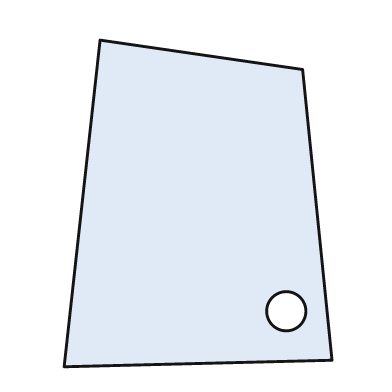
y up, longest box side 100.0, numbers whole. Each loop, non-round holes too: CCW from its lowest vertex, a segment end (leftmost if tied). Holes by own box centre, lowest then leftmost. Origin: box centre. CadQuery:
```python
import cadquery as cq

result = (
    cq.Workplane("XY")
    .moveTo(-41.0, -50.0)
    .lineTo(41.0, -48.0)
    .lineTo(32.0, 41.0)
    .lineTo(-30.0, 50.0)
    .close()
    .moveTo(27.0, -33.0)
    .circle(6.0)
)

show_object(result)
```